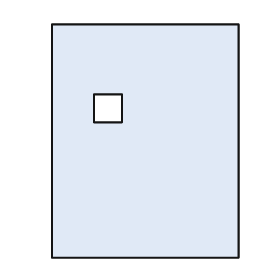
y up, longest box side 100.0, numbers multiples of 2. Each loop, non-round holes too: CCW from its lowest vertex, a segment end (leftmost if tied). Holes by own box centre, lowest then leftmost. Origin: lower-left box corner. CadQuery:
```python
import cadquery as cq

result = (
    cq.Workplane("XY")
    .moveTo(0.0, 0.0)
    .lineTo(80.0, 0.0)
    .lineTo(80.0, 100.0)
    .lineTo(0.0, 100.0)
    .close()
    .moveTo(18.0, 58.0)
    .lineTo(30.0, 58.0)
    .lineTo(30.0, 70.0)
    .lineTo(18.0, 70.0)
    .close()
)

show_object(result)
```